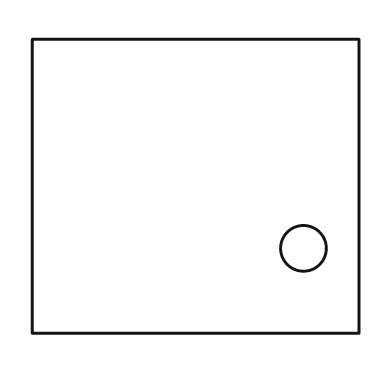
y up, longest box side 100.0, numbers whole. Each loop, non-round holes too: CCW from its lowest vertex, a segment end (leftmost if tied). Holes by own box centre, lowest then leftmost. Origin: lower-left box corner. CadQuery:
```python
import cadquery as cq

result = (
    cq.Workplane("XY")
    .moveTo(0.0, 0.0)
    .lineTo(100.0, 0.0)
    .lineTo(100.0, 90.0)
    .lineTo(0.0, 90.0)
    .close()
    .moveTo(83.0, 26.0)
    .circle(7.0)
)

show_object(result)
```